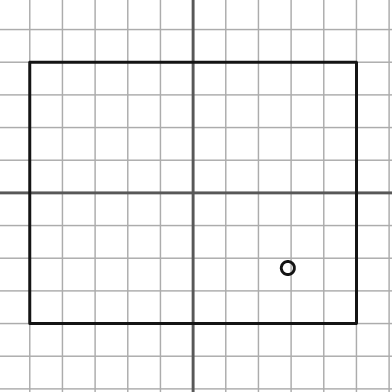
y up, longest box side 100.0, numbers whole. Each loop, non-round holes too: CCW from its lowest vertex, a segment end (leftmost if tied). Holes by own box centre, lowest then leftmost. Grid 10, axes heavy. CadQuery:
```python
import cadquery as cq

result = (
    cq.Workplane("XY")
    .moveTo(-50.0, -40.0)
    .lineTo(50.0, -40.0)
    .lineTo(50.0, 40.0)
    .lineTo(-50.0, 40.0)
    .close()
    .moveTo(29.0, -23.0)
    .circle(2.0)
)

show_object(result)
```